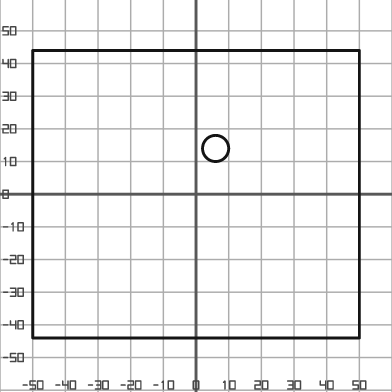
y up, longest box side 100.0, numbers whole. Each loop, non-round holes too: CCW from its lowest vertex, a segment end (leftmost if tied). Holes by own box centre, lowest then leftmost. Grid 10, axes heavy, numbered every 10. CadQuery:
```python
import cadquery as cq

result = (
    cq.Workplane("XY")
    .moveTo(-50.0, -44.0)
    .lineTo(50.0, -44.0)
    .lineTo(50.0, 44.0)
    .lineTo(-50.0, 44.0)
    .close()
    .moveTo(6.0, 14.0)
    .circle(4.0)
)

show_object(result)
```